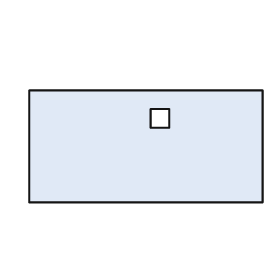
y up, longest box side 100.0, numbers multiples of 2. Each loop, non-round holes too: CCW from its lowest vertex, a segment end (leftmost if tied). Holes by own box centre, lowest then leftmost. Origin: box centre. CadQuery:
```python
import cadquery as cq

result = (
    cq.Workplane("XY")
    .moveTo(-50.0, -24.0)
    .lineTo(50.0, -24.0)
    .lineTo(50.0, 24.0)
    .lineTo(-50.0, 24.0)
    .close()
    .moveTo(2.0, 8.0)
    .lineTo(10.0, 8.0)
    .lineTo(10.0, 16.0)
    .lineTo(2.0, 16.0)
    .close()
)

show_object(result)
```